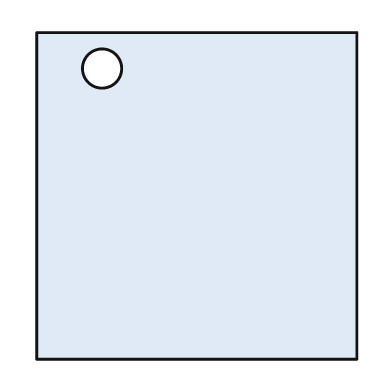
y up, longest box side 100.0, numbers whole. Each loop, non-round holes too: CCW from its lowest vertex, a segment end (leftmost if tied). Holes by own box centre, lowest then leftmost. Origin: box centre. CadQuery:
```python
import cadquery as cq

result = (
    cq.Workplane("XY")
    .moveTo(-49.0, -50.0)
    .lineTo(49.0, -50.0)
    .lineTo(49.0, 50.0)
    .lineTo(-49.0, 50.0)
    .close()
    .moveTo(-29.0, 39.0)
    .circle(6.0)
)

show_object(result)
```